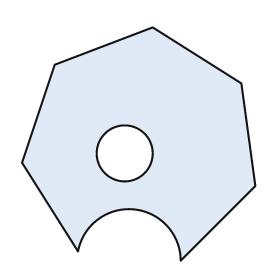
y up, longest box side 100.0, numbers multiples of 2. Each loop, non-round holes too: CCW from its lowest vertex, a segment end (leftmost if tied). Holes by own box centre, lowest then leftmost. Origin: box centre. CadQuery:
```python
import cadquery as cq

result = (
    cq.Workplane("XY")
    .moveTo(18.0, -50.0)
    .lineTo(50.0, -18.0)
    .lineTo(44.0, 26.0)
    .lineTo(6.0, 50.0)
    .lineTo(-36.0, 34.0)
    .lineTo(-50.0, -8.0)
    .lineTo(-26.0, -46.0)
    .threePointArc((-2.0, -28.0), (18.0, -50.0))
    .close()
    .moveTo(-6.0, -4.0)
    .circle(12.0)
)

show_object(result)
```